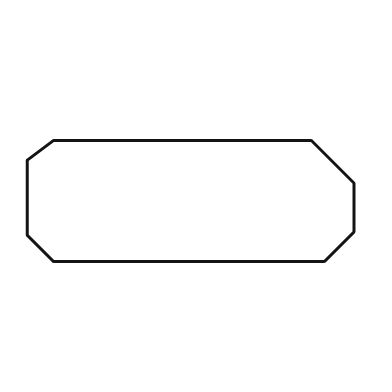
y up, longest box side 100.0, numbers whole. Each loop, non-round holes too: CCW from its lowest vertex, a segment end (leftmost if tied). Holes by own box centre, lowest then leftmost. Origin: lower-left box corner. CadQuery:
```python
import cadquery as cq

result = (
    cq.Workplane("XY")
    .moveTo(8.0, 0.0)
    .lineTo(91.0, 0.0)
    .lineTo(100.0, 9.0)
    .lineTo(100.0, 24.0)
    .lineTo(87.0, 37.0)
    .lineTo(8.0, 37.0)
    .lineTo(0.0, 31.0)
    .lineTo(0.0, 8.0)
    .close()
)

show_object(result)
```